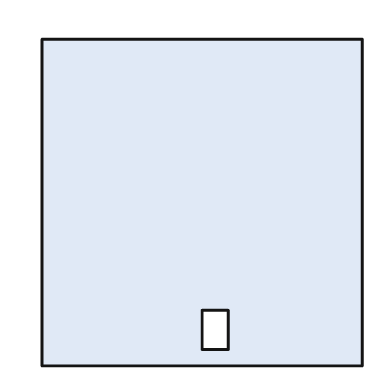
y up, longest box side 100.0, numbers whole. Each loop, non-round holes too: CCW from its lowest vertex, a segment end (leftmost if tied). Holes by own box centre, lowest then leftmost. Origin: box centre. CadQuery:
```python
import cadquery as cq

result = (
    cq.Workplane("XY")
    .moveTo(-49.0, -50.0)
    .lineTo(49.0, -50.0)
    .lineTo(49.0, 50.0)
    .lineTo(-49.0, 50.0)
    .close()
    .moveTo(0.0, -45.0)
    .lineTo(8.0, -45.0)
    .lineTo(8.0, -33.0)
    .lineTo(0.0, -33.0)
    .close()
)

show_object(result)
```